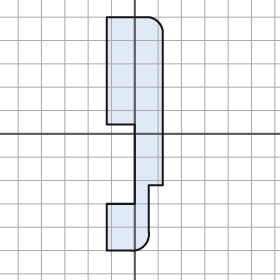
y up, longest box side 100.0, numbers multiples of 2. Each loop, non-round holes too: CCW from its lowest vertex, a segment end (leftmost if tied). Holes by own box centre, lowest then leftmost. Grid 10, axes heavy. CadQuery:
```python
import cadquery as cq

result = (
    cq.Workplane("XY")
    .moveTo(-12.0, -50.0)
    .lineTo(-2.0, -50.0)
    .threePointArc((4.0, -48.0), (6.0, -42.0))
    .lineTo(6.0, -22.0)
    .lineTo(12.0, -22.0)
    .lineTo(12.0, 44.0)
    .threePointArc((10.0, 48.0), (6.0, 50.0))
    .lineTo(-12.0, 50.0)
    .lineTo(-12.0, 4.0)
    .lineTo(0.0, 4.0)
    .lineTo(0.0, -30.0)
    .lineTo(-12.0, -30.0)
    .close()
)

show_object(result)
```